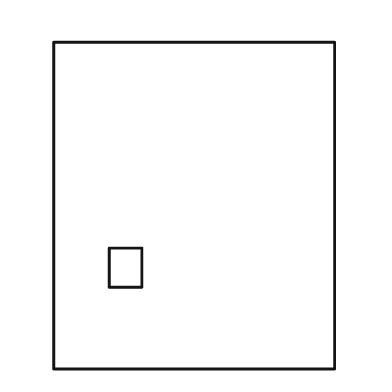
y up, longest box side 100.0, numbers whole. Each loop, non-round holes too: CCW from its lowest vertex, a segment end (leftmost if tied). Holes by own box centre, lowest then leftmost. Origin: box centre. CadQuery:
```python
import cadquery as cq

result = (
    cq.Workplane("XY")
    .moveTo(-43.0, -50.0)
    .lineTo(43.0, -50.0)
    .lineTo(43.0, 50.0)
    .lineTo(-43.0, 50.0)
    .close()
    .moveTo(-26.0, -25.0)
    .lineTo(-16.0, -25.0)
    .lineTo(-16.0, -13.0)
    .lineTo(-26.0, -13.0)
    .close()
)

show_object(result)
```